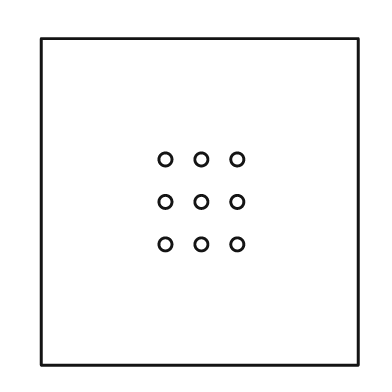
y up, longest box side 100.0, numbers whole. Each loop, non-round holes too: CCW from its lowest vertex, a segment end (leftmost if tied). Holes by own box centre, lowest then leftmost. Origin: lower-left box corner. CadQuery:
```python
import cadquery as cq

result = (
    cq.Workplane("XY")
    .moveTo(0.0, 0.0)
    .lineTo(97.0, 0.0)
    .lineTo(97.0, 100.0)
    .lineTo(0.0, 100.0)
    .close()
    .moveTo(38.0, 37.0)
    .circle(2.0)
    .moveTo(49.0, 37.0)
    .circle(2.0)
    .moveTo(60.0, 37.0)
    .circle(2.0)
    .moveTo(38.0, 50.0)
    .circle(2.0)
    .moveTo(49.0, 50.0)
    .circle(2.0)
    .moveTo(60.0, 50.0)
    .circle(2.0)
    .moveTo(38.0, 63.0)
    .circle(2.0)
    .moveTo(49.0, 63.0)
    .circle(2.0)
    .moveTo(60.0, 63.0)
    .circle(2.0)
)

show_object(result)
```